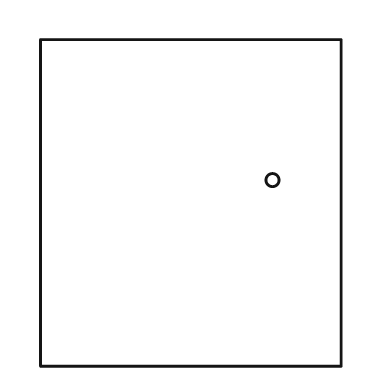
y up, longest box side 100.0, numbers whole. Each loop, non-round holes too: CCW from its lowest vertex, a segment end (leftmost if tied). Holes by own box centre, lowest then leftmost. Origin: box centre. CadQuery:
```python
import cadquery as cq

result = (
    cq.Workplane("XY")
    .moveTo(-46.0, -50.0)
    .lineTo(46.0, -50.0)
    .lineTo(46.0, 50.0)
    .lineTo(-46.0, 50.0)
    .close()
    .moveTo(25.0, 7.0)
    .circle(2.0)
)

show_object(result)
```